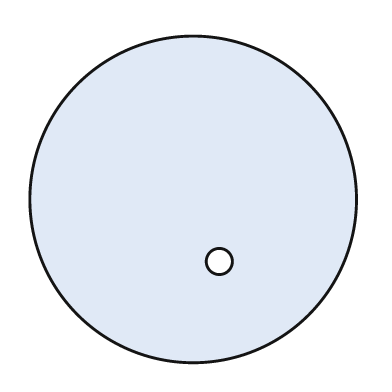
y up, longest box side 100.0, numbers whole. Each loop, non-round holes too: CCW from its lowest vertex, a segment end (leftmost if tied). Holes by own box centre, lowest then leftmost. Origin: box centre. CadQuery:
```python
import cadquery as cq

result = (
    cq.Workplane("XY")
    .moveTo(0.0, 0.0)
    .circle(50.0)
    .moveTo(8.0, -19.0)
    .circle(4.0)
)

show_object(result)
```